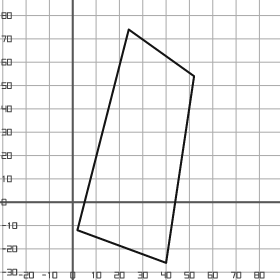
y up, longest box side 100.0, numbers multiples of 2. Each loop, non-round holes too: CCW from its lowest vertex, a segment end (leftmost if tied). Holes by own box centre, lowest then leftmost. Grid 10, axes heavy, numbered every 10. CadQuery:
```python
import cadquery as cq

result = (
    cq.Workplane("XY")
    .moveTo(40.0, -26.0)
    .lineTo(52.0, 54.0)
    .lineTo(24.0, 74.0)
    .lineTo(2.0, -12.0)
    .close()
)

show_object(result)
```